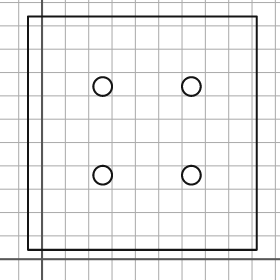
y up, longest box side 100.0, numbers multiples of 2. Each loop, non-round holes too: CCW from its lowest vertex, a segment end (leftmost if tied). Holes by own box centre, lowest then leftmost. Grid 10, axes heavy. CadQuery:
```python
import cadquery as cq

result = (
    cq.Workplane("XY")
    .moveTo(-6.0, 4.0)
    .lineTo(92.0, 4.0)
    .lineTo(92.0, 104.0)
    .lineTo(-6.0, 104.0)
    .close()
    .moveTo(26.0, 36.0)
    .circle(4.0)
    .moveTo(64.0, 36.0)
    .circle(4.0)
    .moveTo(26.0, 74.0)
    .circle(4.0)
    .moveTo(64.0, 74.0)
    .circle(4.0)
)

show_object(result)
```